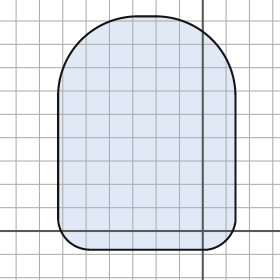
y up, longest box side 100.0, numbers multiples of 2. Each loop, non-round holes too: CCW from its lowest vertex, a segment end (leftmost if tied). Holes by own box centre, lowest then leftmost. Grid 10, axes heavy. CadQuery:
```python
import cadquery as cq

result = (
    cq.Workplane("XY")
    .moveTo(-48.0, -8.0)
    .lineTo(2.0, -8.0)
    .threePointArc((10.0, -4.0), (14.0, 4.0))
    .lineTo(14.0, 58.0)
    .threePointArc((4.0, 82.0), (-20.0, 92.0))
    .lineTo(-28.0, 92.0)
    .threePointArc((-52.0, 82.0), (-62.0, 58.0))
    .lineTo(-62.0, 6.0)
    .threePointArc((-58.0, -4.0), (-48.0, -8.0))
    .close()
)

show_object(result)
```